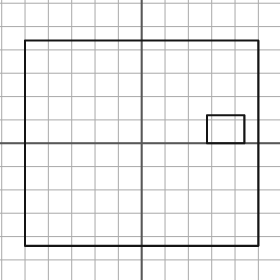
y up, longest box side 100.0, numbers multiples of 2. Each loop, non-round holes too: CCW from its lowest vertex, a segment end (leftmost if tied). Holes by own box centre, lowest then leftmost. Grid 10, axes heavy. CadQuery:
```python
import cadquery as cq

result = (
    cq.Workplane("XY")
    .moveTo(-50.0, -44.0)
    .lineTo(50.0, -44.0)
    .lineTo(50.0, 44.0)
    .lineTo(-50.0, 44.0)
    .close()
    .moveTo(28.0, 0.0)
    .lineTo(44.0, 0.0)
    .lineTo(44.0, 12.0)
    .lineTo(28.0, 12.0)
    .close()
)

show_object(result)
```